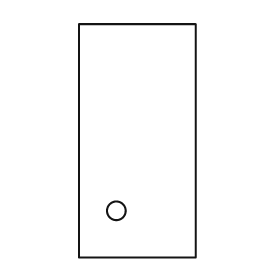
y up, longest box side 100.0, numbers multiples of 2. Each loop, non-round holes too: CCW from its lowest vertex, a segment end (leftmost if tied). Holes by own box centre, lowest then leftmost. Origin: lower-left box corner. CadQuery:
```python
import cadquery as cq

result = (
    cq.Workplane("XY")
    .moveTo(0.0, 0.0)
    .lineTo(50.0, 0.0)
    .lineTo(50.0, 100.0)
    .lineTo(0.0, 100.0)
    .close()
    .moveTo(16.0, 20.0)
    .circle(4.0)
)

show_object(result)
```